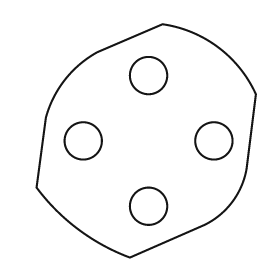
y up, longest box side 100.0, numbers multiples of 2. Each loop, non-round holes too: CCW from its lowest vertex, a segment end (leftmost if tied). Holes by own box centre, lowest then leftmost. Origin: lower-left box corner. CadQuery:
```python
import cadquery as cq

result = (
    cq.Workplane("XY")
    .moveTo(40.0, 0.0)
    .lineTo(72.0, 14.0)
    .threePointArc((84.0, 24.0), (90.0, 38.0))
    .lineTo(94.0, 70.0)
    .threePointArc((78.0, 90.0), (54.0, 100.0))
    .lineTo(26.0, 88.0)
    .threePointArc((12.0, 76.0), (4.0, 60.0))
    .lineTo(0.0, 30.0)
    .threePointArc((18.0, 12.0), (40.0, 0.0))
    .close()
    .moveTo(48.0, 22.0)
    .circle(8.0)
    .moveTo(20.0, 50.0)
    .circle(8.0)
    .moveTo(76.0, 50.0)
    .circle(8.0)
    .moveTo(48.0, 78.0)
    .circle(8.0)
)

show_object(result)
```